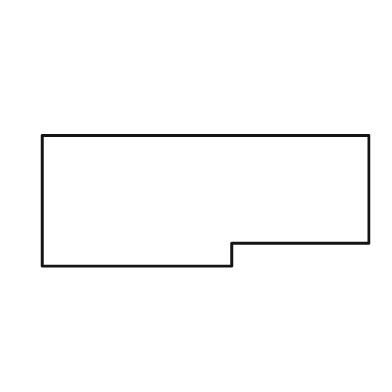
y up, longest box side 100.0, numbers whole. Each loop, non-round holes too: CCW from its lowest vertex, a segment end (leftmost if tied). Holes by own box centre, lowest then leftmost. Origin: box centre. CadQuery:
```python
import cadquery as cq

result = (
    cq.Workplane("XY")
    .moveTo(-50.0, -20.0)
    .lineTo(8.0, -20.0)
    .lineTo(8.0, -13.0)
    .lineTo(50.0, -13.0)
    .lineTo(50.0, 20.0)
    .lineTo(-50.0, 20.0)
    .close()
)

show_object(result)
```